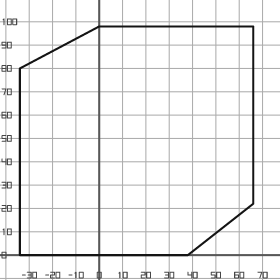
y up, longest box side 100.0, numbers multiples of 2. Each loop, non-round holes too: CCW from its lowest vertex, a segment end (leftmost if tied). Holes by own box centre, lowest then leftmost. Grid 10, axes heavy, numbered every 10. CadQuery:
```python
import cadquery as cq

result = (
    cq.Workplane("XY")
    .moveTo(-34.0, 0.0)
    .lineTo(38.0, 0.0)
    .lineTo(66.0, 22.0)
    .lineTo(66.0, 98.0)
    .lineTo(0.0, 98.0)
    .lineTo(-34.0, 80.0)
    .close()
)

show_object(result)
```